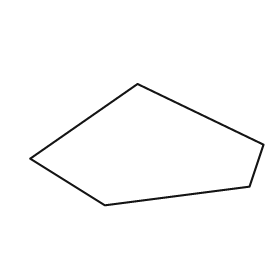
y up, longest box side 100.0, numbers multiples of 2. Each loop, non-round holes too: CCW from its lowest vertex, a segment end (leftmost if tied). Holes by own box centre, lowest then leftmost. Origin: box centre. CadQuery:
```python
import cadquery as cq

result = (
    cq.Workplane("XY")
    .moveTo(-18.0, -26.0)
    .lineTo(44.0, -18.0)
    .lineTo(50.0, 0.0)
    .lineTo(-4.0, 26.0)
    .lineTo(-50.0, -6.0)
    .close()
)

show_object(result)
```